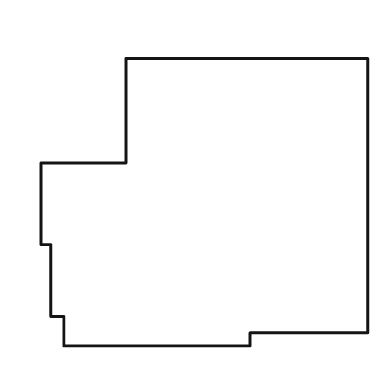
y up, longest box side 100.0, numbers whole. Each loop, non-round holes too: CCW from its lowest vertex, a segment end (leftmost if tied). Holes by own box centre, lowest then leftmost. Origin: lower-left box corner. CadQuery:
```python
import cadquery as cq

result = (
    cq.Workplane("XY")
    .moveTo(7.0, 0.0)
    .lineTo(64.0, 0.0)
    .lineTo(64.0, 4.0)
    .lineTo(100.0, 4.0)
    .lineTo(100.0, 88.0)
    .lineTo(26.0, 88.0)
    .lineTo(26.0, 56.0)
    .lineTo(0.0, 56.0)
    .lineTo(0.0, 31.0)
    .lineTo(3.0, 31.0)
    .lineTo(3.0, 9.0)
    .lineTo(7.0, 9.0)
    .close()
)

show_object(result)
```